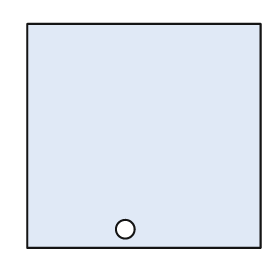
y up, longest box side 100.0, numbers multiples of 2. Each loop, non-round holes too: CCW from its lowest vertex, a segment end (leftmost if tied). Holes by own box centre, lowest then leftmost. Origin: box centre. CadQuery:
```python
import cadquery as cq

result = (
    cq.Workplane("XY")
    .moveTo(-50.0, -48.0)
    .lineTo(50.0, -48.0)
    .lineTo(50.0, 48.0)
    .lineTo(-50.0, 48.0)
    .close()
    .moveTo(-8.0, -40.0)
    .circle(4.0)
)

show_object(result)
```